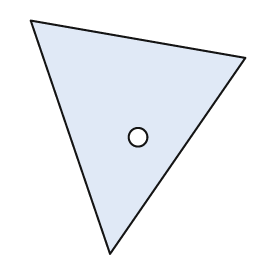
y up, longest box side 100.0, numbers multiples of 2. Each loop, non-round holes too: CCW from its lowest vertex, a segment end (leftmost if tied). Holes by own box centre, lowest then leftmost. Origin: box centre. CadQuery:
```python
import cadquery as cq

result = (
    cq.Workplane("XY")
    .moveTo(-12.0, -50.0)
    .lineTo(46.0, 34.0)
    .lineTo(-46.0, 50.0)
    .close()
    .moveTo(0.0, 0.0)
    .circle(4.0)
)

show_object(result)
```